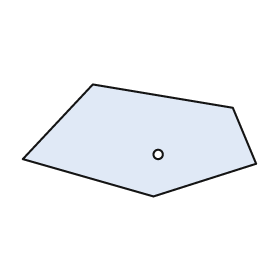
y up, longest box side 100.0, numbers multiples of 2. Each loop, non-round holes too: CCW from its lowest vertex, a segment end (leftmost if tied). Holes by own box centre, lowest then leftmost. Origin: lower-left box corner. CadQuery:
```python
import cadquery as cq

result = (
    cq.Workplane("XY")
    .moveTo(56.0, 0.0)
    .lineTo(100.0, 14.0)
    .lineTo(90.0, 38.0)
    .lineTo(30.0, 48.0)
    .lineTo(0.0, 16.0)
    .close()
    .moveTo(58.0, 18.0)
    .circle(2.0)
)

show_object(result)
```